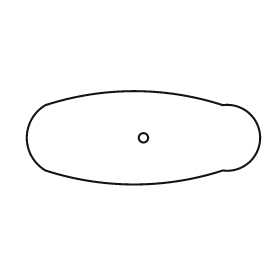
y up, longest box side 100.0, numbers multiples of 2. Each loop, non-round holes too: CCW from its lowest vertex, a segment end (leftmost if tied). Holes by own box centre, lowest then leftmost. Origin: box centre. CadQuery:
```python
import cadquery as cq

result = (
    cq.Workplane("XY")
    .moveTo(-42.0, -14.0)
    .threePointArc((-4.0, -20.0), (34.0, -14.0))
    .threePointArc((50.0, 0.0), (34.0, 14.0))
    .threePointArc((-4.0, 20.0), (-42.0, 14.0))
    .threePointArc((-50.0, 0.0), (-42.0, -14.0))
    .close()
    .moveTo(0.0, 0.0)
    .circle(2.0)
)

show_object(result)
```